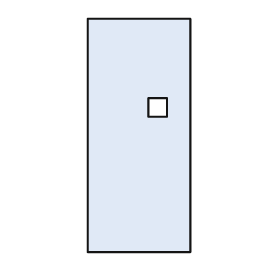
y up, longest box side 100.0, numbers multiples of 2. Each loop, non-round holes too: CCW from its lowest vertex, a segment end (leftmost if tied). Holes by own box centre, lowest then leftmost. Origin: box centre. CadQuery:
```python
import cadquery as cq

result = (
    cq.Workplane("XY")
    .moveTo(-22.0, -50.0)
    .lineTo(22.0, -50.0)
    .lineTo(22.0, 50.0)
    .lineTo(-22.0, 50.0)
    .close()
    .moveTo(4.0, 8.0)
    .lineTo(12.0, 8.0)
    .lineTo(12.0, 16.0)
    .lineTo(4.0, 16.0)
    .close()
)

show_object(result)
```